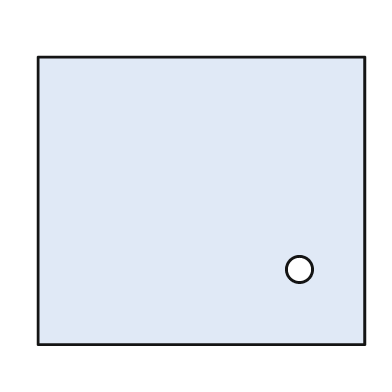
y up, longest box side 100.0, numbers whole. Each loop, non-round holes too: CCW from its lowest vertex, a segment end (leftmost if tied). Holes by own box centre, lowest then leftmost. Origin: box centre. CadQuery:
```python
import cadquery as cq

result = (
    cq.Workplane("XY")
    .moveTo(-50.0, -44.0)
    .lineTo(50.0, -44.0)
    .lineTo(50.0, 44.0)
    .lineTo(-50.0, 44.0)
    .close()
    .moveTo(30.0, -21.0)
    .circle(4.0)
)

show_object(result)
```